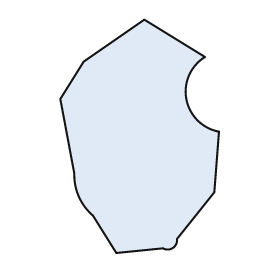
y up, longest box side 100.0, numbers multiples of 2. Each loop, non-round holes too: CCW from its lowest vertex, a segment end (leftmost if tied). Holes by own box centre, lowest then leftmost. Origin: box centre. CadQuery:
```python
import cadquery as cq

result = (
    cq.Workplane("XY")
    .moveTo(-10.0, -50.0)
    .lineTo(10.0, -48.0)
    .threePointArc((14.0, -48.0), (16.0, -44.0))
    .lineTo(32.0, -24.0)
    .lineTo(34.0, 2.0)
    .threePointArc((20.0, 16.0), (28.0, 34.0))
    .lineTo(2.0, 50.0)
    .lineTo(-24.0, 32.0)
    .lineTo(-34.0, 16.0)
    .lineTo(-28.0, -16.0)
    .threePointArc((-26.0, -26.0), (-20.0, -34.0))
    .close()
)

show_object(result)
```